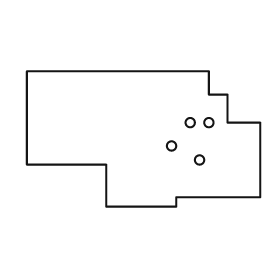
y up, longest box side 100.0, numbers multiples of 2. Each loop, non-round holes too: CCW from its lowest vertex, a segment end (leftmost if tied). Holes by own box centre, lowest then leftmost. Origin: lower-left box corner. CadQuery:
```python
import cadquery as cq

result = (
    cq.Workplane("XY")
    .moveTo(34.0, 0.0)
    .lineTo(64.0, 0.0)
    .lineTo(64.0, 4.0)
    .lineTo(100.0, 4.0)
    .lineTo(100.0, 36.0)
    .lineTo(86.0, 36.0)
    .lineTo(86.0, 48.0)
    .lineTo(78.0, 48.0)
    .lineTo(78.0, 58.0)
    .lineTo(0.0, 58.0)
    .lineTo(0.0, 18.0)
    .lineTo(34.0, 18.0)
    .close()
    .moveTo(74.0, 20.0)
    .circle(2.0)
    .moveTo(62.0, 26.0)
    .circle(2.0)
    .moveTo(70.0, 36.0)
    .circle(2.0)
    .moveTo(78.0, 36.0)
    .circle(2.0)
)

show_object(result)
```